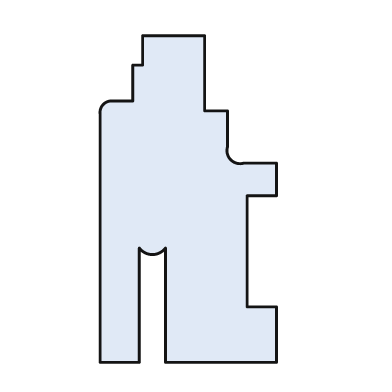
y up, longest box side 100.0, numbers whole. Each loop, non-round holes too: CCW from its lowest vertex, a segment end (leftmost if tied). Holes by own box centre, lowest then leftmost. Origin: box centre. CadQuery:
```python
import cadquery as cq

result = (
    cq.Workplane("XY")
    .moveTo(-27.0, -50.0)
    .lineTo(-15.0, -50.0)
    .lineTo(-15.0, -15.0)
    .threePointArc((-11.0, -17.0), (-7.0, -15.0))
    .lineTo(-7.0, -50.0)
    .lineTo(27.0, -50.0)
    .lineTo(27.0, -33.0)
    .lineTo(18.0, -33.0)
    .lineTo(18.0, 1.0)
    .lineTo(27.0, 1.0)
    .lineTo(27.0, 11.0)
    .lineTo(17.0, 11.0)
    .threePointArc((13.0, 12.0), (12.0, 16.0))
    .lineTo(12.0, 27.0)
    .lineTo(5.0, 27.0)
    .lineTo(5.0, 50.0)
    .lineTo(-14.0, 50.0)
    .lineTo(-14.0, 41.0)
    .lineTo(-17.0, 41.0)
    .lineTo(-17.0, 30.0)
    .lineTo(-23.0, 30.0)
    .threePointArc((-26.0, 29.0), (-27.0, 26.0))
    .close()
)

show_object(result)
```